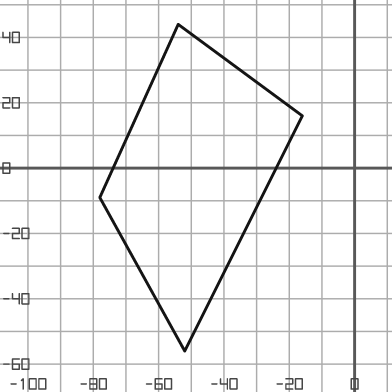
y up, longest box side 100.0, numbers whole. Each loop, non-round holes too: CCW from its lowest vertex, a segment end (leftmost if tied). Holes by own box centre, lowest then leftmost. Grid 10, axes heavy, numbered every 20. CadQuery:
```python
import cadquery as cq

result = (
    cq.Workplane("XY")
    .moveTo(-52.0, -56.0)
    .lineTo(-16.0, 16.0)
    .lineTo(-54.0, 44.0)
    .lineTo(-78.0, -9.0)
    .close()
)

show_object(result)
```